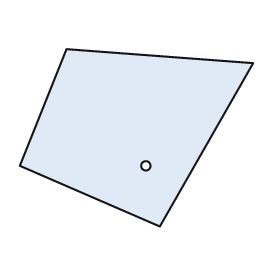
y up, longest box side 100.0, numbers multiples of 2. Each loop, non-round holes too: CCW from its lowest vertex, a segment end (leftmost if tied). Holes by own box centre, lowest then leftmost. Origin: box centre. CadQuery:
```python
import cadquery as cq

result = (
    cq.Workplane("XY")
    .moveTo(10.0, -38.0)
    .lineTo(50.0, 32.0)
    .lineTo(-30.0, 38.0)
    .lineTo(-50.0, -12.0)
    .close()
    .moveTo(4.0, -12.0)
    .circle(2.0)
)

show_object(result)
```